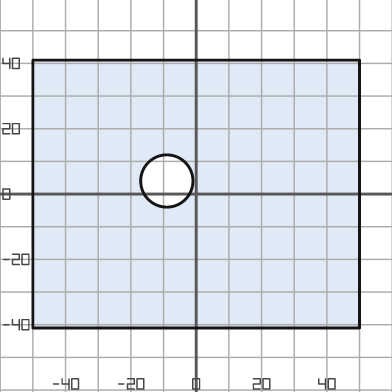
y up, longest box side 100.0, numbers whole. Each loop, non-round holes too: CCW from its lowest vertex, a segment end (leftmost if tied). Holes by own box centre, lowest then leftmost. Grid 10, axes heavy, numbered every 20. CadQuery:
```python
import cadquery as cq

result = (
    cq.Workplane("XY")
    .moveTo(-50.0, -41.0)
    .lineTo(50.0, -41.0)
    .lineTo(50.0, 41.0)
    .lineTo(-50.0, 41.0)
    .close()
    .moveTo(-9.0, 4.0)
    .circle(8.0)
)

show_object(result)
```